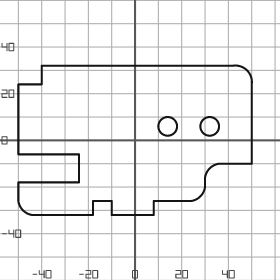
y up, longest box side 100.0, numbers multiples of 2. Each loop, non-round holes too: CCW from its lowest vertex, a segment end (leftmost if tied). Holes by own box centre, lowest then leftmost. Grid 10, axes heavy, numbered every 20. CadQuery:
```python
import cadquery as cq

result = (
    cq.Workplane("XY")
    .moveTo(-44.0, -32.0)
    .lineTo(-18.0, -32.0)
    .lineTo(-18.0, -26.0)
    .lineTo(-10.0, -26.0)
    .lineTo(-10.0, -32.0)
    .lineTo(8.0, -32.0)
    .lineTo(8.0, -26.0)
    .lineTo(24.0, -26.0)
    .threePointArc((28.0, -24.0), (30.0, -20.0))
    .lineTo(30.0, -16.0)
    .threePointArc((32.0, -12.0), (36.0, -10.0))
    .lineTo(50.0, -10.0)
    .lineTo(50.0, 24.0)
    .threePointArc((48.0, 30.0), (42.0, 32.0))
    .lineTo(-40.0, 32.0)
    .lineTo(-40.0, 24.0)
    .lineTo(-50.0, 24.0)
    .lineTo(-50.0, -6.0)
    .lineTo(-24.0, -6.0)
    .lineTo(-24.0, -18.0)
    .lineTo(-50.0, -18.0)
    .lineTo(-50.0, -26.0)
    .threePointArc((-48.0, -30.0), (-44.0, -32.0))
    .close()
    .moveTo(14.0, 6.0)
    .circle(4.0)
    .moveTo(32.0, 6.0)
    .circle(4.0)
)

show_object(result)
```